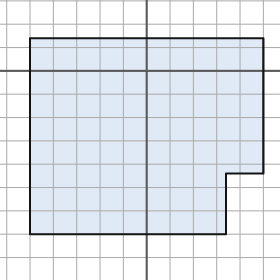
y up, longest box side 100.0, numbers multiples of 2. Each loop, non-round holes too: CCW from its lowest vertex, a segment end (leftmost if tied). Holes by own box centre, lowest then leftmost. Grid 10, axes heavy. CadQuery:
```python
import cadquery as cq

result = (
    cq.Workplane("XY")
    .moveTo(-50.0, -70.0)
    .lineTo(34.0, -70.0)
    .lineTo(34.0, -44.0)
    .lineTo(50.0, -44.0)
    .lineTo(50.0, 14.0)
    .lineTo(-50.0, 14.0)
    .close()
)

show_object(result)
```